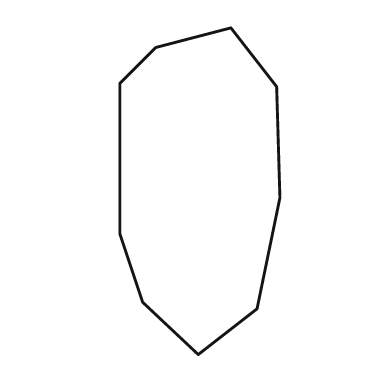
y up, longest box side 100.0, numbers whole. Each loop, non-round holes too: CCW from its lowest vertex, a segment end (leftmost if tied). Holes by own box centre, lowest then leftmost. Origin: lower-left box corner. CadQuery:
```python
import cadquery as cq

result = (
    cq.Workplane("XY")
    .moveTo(24.0, 0.0)
    .lineTo(42.0, 14.0)
    .lineTo(49.0, 48.0)
    .lineTo(48.0, 82.0)
    .lineTo(34.0, 100.0)
    .lineTo(11.0, 94.0)
    .lineTo(0.0, 83.0)
    .lineTo(0.0, 37.0)
    .lineTo(7.0, 16.0)
    .close()
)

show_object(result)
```